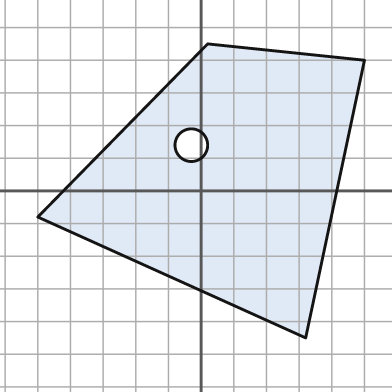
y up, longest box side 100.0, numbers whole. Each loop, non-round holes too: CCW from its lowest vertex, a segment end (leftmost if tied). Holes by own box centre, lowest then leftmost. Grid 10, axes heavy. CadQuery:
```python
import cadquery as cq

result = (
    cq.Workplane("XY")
    .moveTo(32.0, -45.0)
    .lineTo(50.0, 40.0)
    .lineTo(2.0, 45.0)
    .lineTo(-50.0, -8.0)
    .close()
    .moveTo(-3.0, 14.0)
    .circle(5.0)
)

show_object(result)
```